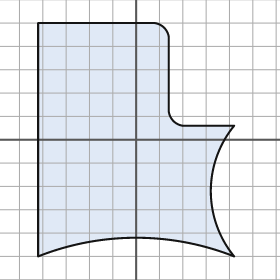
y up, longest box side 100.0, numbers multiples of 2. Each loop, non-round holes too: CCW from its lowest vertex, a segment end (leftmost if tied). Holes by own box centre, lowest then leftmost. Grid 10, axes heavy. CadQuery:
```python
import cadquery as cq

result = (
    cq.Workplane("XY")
    .moveTo(-42.0, -50.0)
    .threePointArc((0.0, -42.0), (42.0, -50.0))
    .threePointArc((32.0, -22.0), (42.0, 6.0))
    .lineTo(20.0, 6.0)
    .threePointArc((16.0, 8.0), (14.0, 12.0))
    .lineTo(14.0, 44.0)
    .threePointArc((12.0, 48.0), (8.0, 50.0))
    .lineTo(-42.0, 50.0)
    .close()
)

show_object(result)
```